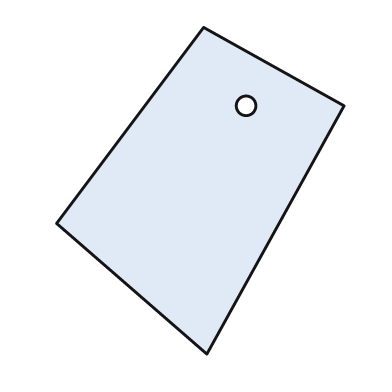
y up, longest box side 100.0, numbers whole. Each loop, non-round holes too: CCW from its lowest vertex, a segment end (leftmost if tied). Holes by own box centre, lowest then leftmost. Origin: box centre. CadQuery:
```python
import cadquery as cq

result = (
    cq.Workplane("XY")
    .moveTo(2.0, -50.0)
    .lineTo(44.0, 26.0)
    .lineTo(1.0, 50.0)
    .lineTo(-44.0, -10.0)
    .close()
    .moveTo(14.0, 26.0)
    .circle(3.0)
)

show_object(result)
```